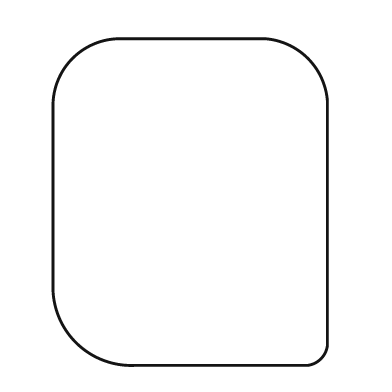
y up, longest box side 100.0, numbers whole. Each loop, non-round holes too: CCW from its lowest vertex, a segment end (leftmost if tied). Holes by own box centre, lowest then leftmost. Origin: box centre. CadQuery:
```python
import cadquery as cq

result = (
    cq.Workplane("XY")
    .moveTo(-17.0, -50.0)
    .lineTo(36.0, -50.0)
    .threePointArc((40.0, -48.0), (42.0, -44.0))
    .lineTo(42.0, 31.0)
    .threePointArc((36.0, 44.0), (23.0, 50.0))
    .lineTo(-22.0, 50.0)
    .threePointArc((-36.0, 44.0), (-42.0, 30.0))
    .lineTo(-42.0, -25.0)
    .threePointArc((-35.0, -43.0), (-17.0, -50.0))
    .close()
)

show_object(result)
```